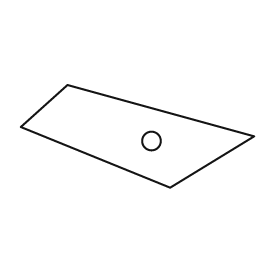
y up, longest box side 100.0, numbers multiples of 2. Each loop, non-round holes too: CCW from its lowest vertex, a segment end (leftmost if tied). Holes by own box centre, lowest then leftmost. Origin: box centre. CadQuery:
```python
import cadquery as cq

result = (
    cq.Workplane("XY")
    .moveTo(14.0, -22.0)
    .lineTo(50.0, 0.0)
    .lineTo(-30.0, 22.0)
    .lineTo(-50.0, 4.0)
    .close()
    .moveTo(6.0, -2.0)
    .circle(4.0)
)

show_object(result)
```